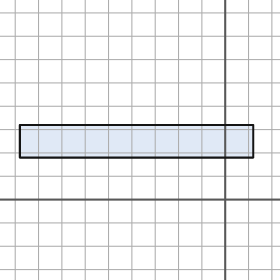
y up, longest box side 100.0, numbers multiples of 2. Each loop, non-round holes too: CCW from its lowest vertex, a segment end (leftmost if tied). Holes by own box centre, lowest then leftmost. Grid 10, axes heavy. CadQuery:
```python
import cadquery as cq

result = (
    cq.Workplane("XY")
    .moveTo(-88.0, 18.0)
    .lineTo(12.0, 18.0)
    .lineTo(12.0, 32.0)
    .lineTo(-88.0, 32.0)
    .close()
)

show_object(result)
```